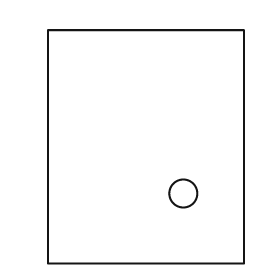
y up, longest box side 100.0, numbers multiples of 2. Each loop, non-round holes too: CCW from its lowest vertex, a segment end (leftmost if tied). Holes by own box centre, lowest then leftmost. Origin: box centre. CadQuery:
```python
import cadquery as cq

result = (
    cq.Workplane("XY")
    .moveTo(-42.0, -50.0)
    .lineTo(42.0, -50.0)
    .lineTo(42.0, 50.0)
    .lineTo(-42.0, 50.0)
    .close()
    .moveTo(16.0, -20.0)
    .circle(6.0)
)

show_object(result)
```